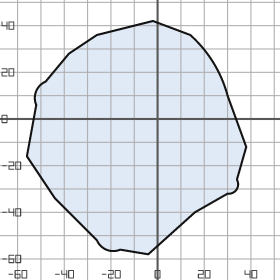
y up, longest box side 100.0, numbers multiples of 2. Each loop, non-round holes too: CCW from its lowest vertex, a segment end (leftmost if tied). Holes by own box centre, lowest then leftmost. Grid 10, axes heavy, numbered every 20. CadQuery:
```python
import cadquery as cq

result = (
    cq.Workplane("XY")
    .moveTo(-4.0, -58.0)
    .lineTo(16.0, -40.0)
    .lineTo(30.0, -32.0)
    .threePointArc((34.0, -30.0), (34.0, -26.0))
    .lineTo(38.0, -12.0)
    .lineTo(30.0, 10.0)
    .threePointArc((24.0, 24.0), (14.0, 36.0))
    .lineTo(-2.0, 42.0)
    .lineTo(-26.0, 36.0)
    .lineTo(-38.0, 28.0)
    .lineTo(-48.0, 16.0)
    .threePointArc((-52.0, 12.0), (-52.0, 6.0))
    .lineTo(-56.0, -16.0)
    .lineTo(-44.0, -34.0)
    .lineTo(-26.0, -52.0)
    .threePointArc((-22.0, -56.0), (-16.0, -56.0))
    .close()
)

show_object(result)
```